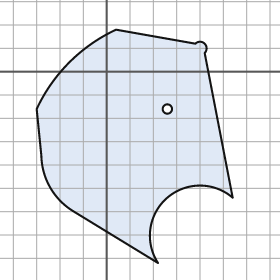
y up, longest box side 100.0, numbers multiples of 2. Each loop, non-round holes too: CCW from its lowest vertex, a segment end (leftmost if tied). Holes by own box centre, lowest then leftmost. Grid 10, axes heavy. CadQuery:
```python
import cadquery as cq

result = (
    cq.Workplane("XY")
    .moveTo(22.0, -82.0)
    .threePointArc((26.0, -54.0), (54.0, -54.0))
    .lineTo(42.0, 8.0)
    .threePointArc((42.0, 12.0), (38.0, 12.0))
    .lineTo(4.0, 18.0)
    .threePointArc((-16.0, 4.0), (-30.0, -16.0))
    .lineTo(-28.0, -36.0)
    .threePointArc((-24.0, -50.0), (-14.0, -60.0))
    .close()
    .moveTo(26.0, -16.0)
    .circle(2.0)
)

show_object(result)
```